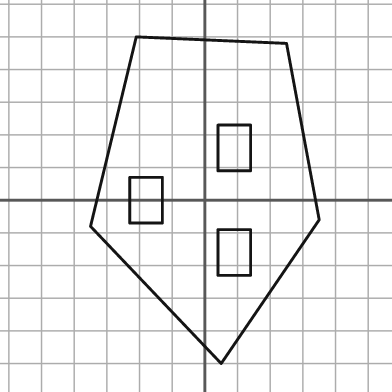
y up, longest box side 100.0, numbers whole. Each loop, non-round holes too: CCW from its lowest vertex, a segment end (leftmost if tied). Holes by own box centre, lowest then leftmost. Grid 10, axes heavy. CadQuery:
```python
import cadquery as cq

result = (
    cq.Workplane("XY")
    .moveTo(5.0, -50.0)
    .lineTo(35.0, -6.0)
    .lineTo(25.0, 48.0)
    .lineTo(-21.0, 50.0)
    .lineTo(-35.0, -8.0)
    .close()
    .moveTo(4.0, -23.0)
    .lineTo(14.0, -23.0)
    .lineTo(14.0, -9.0)
    .lineTo(4.0, -9.0)
    .close()
    .moveTo(-23.0, -7.0)
    .lineTo(-13.0, -7.0)
    .lineTo(-13.0, 7.0)
    .lineTo(-23.0, 7.0)
    .close()
    .moveTo(4.0, 9.0)
    .lineTo(14.0, 9.0)
    .lineTo(14.0, 23.0)
    .lineTo(4.0, 23.0)
    .close()
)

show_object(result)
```